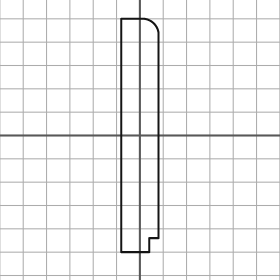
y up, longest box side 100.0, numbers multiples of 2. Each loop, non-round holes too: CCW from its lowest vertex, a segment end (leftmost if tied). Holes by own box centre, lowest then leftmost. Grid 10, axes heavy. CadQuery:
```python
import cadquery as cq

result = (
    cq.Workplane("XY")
    .moveTo(-8.0, -50.0)
    .lineTo(4.0, -50.0)
    .lineTo(4.0, -44.0)
    .lineTo(8.0, -44.0)
    .lineTo(8.0, 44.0)
    .threePointArc((6.0, 48.0), (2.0, 50.0))
    .lineTo(-8.0, 50.0)
    .close()
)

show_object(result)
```